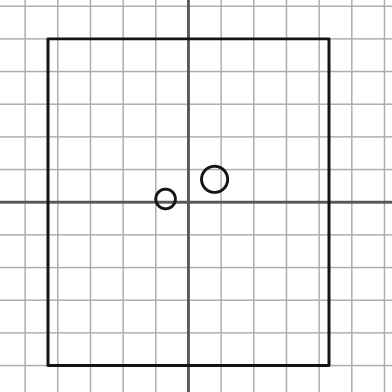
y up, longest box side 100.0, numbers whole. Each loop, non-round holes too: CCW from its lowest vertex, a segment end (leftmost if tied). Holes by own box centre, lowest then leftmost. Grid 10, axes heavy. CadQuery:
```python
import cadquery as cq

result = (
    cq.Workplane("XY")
    .moveTo(-43.0, -50.0)
    .lineTo(43.0, -50.0)
    .lineTo(43.0, 50.0)
    .lineTo(-43.0, 50.0)
    .close()
    .moveTo(-7.0, 1.0)
    .circle(3.0)
    .moveTo(8.0, 7.0)
    .circle(4.0)
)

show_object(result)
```